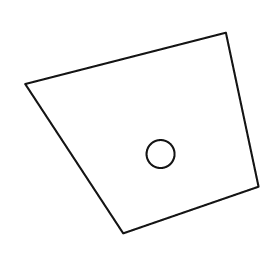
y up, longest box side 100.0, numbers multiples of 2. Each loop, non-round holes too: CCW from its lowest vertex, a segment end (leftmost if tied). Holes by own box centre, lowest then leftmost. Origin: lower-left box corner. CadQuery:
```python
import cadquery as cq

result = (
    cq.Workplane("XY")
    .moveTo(42.0, 0.0)
    .lineTo(100.0, 20.0)
    .lineTo(86.0, 86.0)
    .lineTo(0.0, 64.0)
    .close()
    .moveTo(58.0, 34.0)
    .circle(6.0)
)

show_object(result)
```